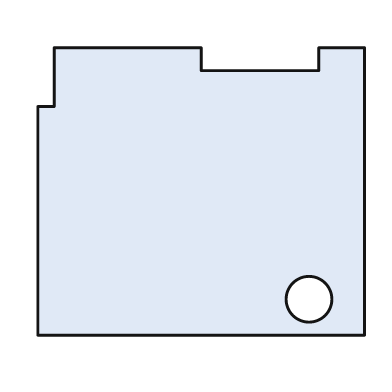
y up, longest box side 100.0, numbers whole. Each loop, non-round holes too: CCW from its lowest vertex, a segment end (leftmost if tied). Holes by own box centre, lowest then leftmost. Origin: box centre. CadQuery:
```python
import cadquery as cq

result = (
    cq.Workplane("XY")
    .moveTo(-50.0, -44.0)
    .lineTo(50.0, -44.0)
    .lineTo(50.0, 44.0)
    .lineTo(36.0, 44.0)
    .lineTo(36.0, 37.0)
    .lineTo(0.0, 37.0)
    .lineTo(0.0, 44.0)
    .lineTo(-45.0, 44.0)
    .lineTo(-45.0, 26.0)
    .lineTo(-50.0, 26.0)
    .close()
    .moveTo(33.0, -33.0)
    .circle(7.0)
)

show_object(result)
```